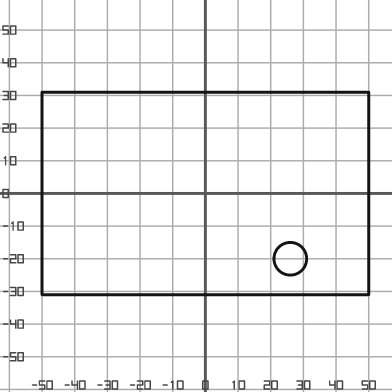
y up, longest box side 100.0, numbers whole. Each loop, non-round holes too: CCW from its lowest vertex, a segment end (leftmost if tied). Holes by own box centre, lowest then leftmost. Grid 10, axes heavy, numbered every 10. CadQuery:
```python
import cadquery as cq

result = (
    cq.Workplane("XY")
    .moveTo(-50.0, -31.0)
    .lineTo(50.0, -31.0)
    .lineTo(50.0, 31.0)
    .lineTo(-50.0, 31.0)
    .close()
    .moveTo(26.0, -20.0)
    .circle(5.0)
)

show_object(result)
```